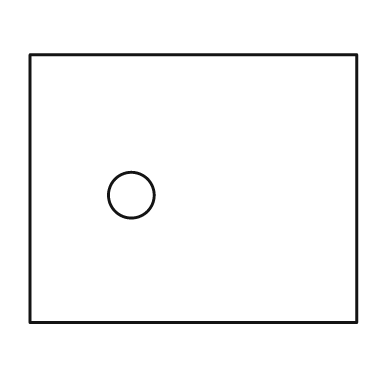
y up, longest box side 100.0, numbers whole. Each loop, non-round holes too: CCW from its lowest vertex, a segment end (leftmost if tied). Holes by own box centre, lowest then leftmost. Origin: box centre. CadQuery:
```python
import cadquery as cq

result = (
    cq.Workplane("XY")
    .moveTo(-50.0, -41.0)
    .lineTo(50.0, -41.0)
    .lineTo(50.0, 41.0)
    .lineTo(-50.0, 41.0)
    .close()
    .moveTo(-19.0, -2.0)
    .circle(7.0)
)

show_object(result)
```